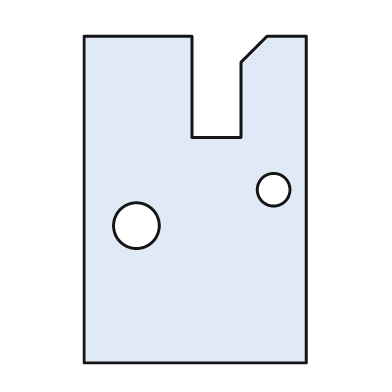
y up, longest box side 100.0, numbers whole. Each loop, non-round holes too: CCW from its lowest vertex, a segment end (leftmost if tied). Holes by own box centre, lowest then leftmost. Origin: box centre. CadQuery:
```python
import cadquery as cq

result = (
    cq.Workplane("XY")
    .moveTo(-34.0, -50.0)
    .lineTo(34.0, -50.0)
    .lineTo(34.0, 50.0)
    .lineTo(22.0, 50.0)
    .lineTo(14.0, 42.0)
    .lineTo(14.0, 19.0)
    .lineTo(-1.0, 19.0)
    .lineTo(-1.0, 50.0)
    .lineTo(-34.0, 50.0)
    .close()
    .moveTo(-18.0, -8.0)
    .circle(7.0)
    .moveTo(24.0, 3.0)
    .circle(5.0)
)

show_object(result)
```